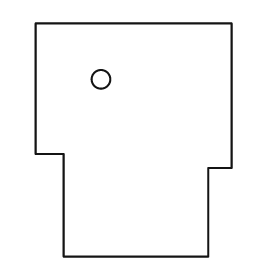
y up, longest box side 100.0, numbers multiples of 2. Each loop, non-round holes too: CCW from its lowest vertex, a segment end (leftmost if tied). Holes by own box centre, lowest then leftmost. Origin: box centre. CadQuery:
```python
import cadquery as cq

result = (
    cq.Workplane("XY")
    .moveTo(-30.0, -50.0)
    .lineTo(32.0, -50.0)
    .lineTo(32.0, -12.0)
    .lineTo(42.0, -12.0)
    .lineTo(42.0, 50.0)
    .lineTo(-42.0, 50.0)
    .lineTo(-42.0, -6.0)
    .lineTo(-30.0, -6.0)
    .close()
    .moveTo(-14.0, 26.0)
    .circle(4.0)
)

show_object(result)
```